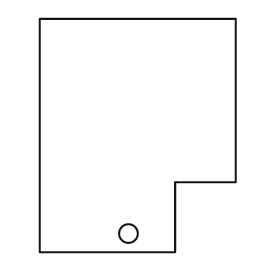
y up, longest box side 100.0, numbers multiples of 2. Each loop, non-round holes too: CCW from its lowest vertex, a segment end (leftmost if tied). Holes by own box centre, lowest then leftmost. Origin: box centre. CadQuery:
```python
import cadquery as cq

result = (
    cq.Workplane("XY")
    .moveTo(-42.0, -50.0)
    .lineTo(16.0, -50.0)
    .lineTo(16.0, -20.0)
    .lineTo(42.0, -20.0)
    .lineTo(42.0, 50.0)
    .lineTo(-42.0, 50.0)
    .close()
    .moveTo(-4.0, -42.0)
    .circle(4.0)
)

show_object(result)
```